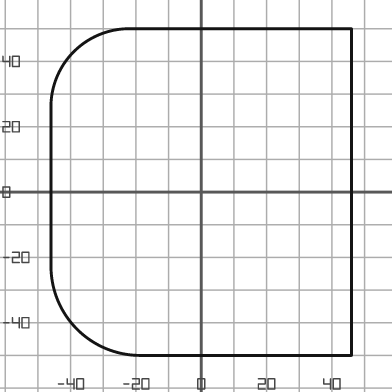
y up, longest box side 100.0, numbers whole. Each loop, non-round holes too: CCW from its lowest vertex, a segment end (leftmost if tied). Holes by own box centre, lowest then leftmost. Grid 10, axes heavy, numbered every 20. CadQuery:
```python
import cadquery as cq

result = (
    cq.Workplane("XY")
    .moveTo(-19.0, -50.0)
    .lineTo(46.0, -50.0)
    .lineTo(46.0, 50.0)
    .lineTo(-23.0, 50.0)
    .threePointArc((-39.0, 43.0), (-46.0, 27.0))
    .lineTo(-46.0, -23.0)
    .threePointArc((-38.0, -42.0), (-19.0, -50.0))
    .close()
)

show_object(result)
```